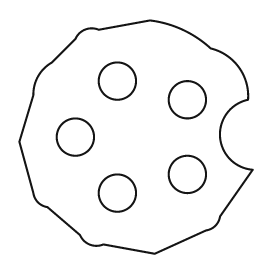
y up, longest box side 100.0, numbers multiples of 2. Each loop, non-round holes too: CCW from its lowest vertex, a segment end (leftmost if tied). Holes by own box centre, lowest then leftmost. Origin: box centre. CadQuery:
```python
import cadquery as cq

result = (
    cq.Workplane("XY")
    .moveTo(8.0, -50.0)
    .lineTo(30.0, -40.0)
    .threePointArc((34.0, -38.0), (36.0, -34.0))
    .lineTo(50.0, -14.0)
    .threePointArc((36.0, 0.0), (48.0, 16.0))
    .threePointArc((44.0, 30.0), (32.0, 38.0))
    .threePointArc((20.0, 46.0), (6.0, 50.0))
    .lineTo(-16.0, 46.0)
    .threePointArc((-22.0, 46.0), (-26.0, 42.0))
    .lineTo(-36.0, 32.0)
    .threePointArc((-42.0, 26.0), (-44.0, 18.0))
    .lineTo(-50.0, -2.0)
    .lineTo(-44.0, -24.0)
    .threePointArc((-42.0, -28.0), (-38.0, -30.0))
    .lineTo(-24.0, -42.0)
    .threePointArc((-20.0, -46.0), (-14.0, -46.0))
    .close()
    .moveTo(-8.0, -24.0)
    .circle(8.0)
    .moveTo(22.0, -16.0)
    .circle(8.0)
    .moveTo(-26.0, 0.0)
    .circle(8.0)
    .moveTo(22.0, 16.0)
    .circle(8.0)
    .moveTo(-8.0, 24.0)
    .circle(8.0)
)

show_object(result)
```